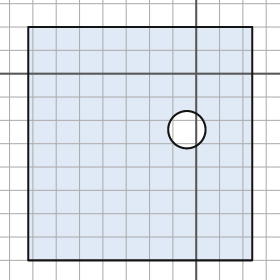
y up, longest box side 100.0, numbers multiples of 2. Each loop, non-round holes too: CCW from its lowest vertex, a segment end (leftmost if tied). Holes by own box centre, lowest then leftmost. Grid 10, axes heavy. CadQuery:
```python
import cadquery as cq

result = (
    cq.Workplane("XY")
    .moveTo(-72.0, -80.0)
    .lineTo(24.0, -80.0)
    .lineTo(24.0, 20.0)
    .lineTo(-72.0, 20.0)
    .close()
    .moveTo(-4.0, -24.0)
    .circle(8.0)
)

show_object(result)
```